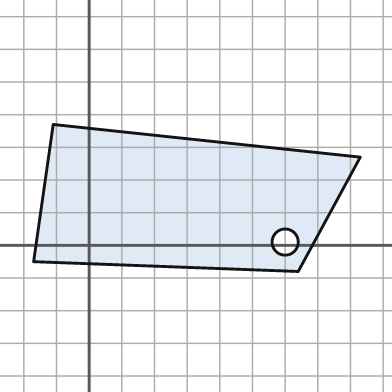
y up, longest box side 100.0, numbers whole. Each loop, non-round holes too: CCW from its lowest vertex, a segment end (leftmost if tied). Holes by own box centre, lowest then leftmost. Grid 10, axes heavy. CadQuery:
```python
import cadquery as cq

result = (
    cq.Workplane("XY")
    .moveTo(64.0, -8.0)
    .lineTo(83.0, 27.0)
    .lineTo(-11.0, 37.0)
    .lineTo(-17.0, -5.0)
    .close()
    .moveTo(60.0, 1.0)
    .circle(4.0)
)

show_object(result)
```